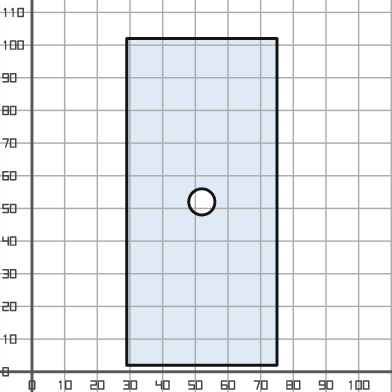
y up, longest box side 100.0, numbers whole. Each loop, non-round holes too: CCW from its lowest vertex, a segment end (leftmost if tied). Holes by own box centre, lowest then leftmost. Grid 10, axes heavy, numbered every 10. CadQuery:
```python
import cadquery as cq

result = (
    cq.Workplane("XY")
    .moveTo(29.0, 2.0)
    .lineTo(75.0, 2.0)
    .lineTo(75.0, 102.0)
    .lineTo(29.0, 102.0)
    .close()
    .moveTo(52.0, 52.0)
    .circle(4.0)
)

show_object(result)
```